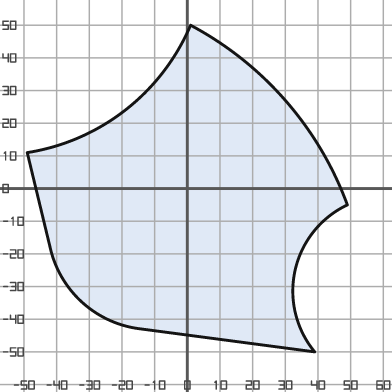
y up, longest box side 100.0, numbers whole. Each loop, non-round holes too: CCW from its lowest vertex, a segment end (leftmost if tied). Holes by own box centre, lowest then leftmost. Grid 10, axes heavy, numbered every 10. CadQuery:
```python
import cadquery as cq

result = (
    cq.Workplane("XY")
    .moveTo(39.0, -50.0)
    .threePointArc((33.0, -25.0), (49.0, -5.0))
    .threePointArc((30.0, 27.0), (1.0, 50.0))
    .threePointArc((-19.0, 24.0), (-49.0, 11.0))
    .lineTo(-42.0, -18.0)
    .threePointArc((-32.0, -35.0), (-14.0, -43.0))
    .close()
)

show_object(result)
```